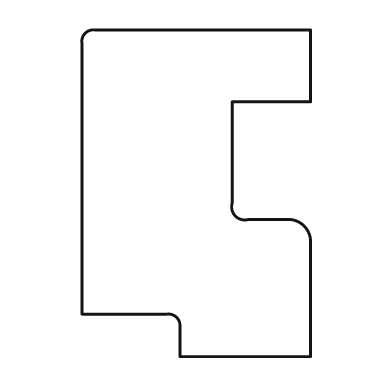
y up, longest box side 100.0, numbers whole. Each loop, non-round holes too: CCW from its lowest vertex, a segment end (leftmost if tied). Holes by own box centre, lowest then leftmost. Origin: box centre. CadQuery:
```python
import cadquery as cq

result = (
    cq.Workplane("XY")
    .moveTo(-5.0, -50.0)
    .lineTo(35.0, -50.0)
    .lineTo(35.0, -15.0)
    .threePointArc((33.0, -10.0), (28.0, -8.0))
    .lineTo(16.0, -8.0)
    .threePointArc((12.0, -7.0), (11.0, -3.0))
    .lineTo(11.0, 28.0)
    .lineTo(35.0, 28.0)
    .lineTo(35.0, 50.0)
    .lineTo(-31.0, 50.0)
    .threePointArc((-34.0, 49.0), (-35.0, 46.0))
    .lineTo(-35.0, -37.0)
    .lineTo(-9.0, -37.0)
    .threePointArc((-6.0, -38.0), (-5.0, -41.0))
    .close()
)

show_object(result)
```